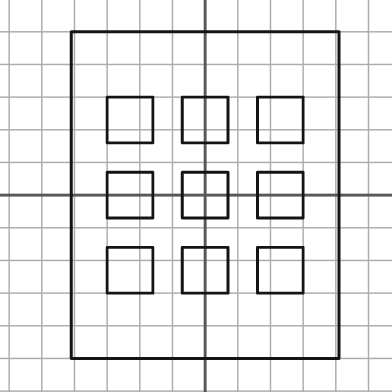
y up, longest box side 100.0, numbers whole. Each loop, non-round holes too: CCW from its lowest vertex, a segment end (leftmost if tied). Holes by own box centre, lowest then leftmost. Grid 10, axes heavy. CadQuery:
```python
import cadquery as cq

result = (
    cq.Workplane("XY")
    .moveTo(-41.0, -50.0)
    .lineTo(41.0, -50.0)
    .lineTo(41.0, 50.0)
    .lineTo(-41.0, 50.0)
    .close()
    .moveTo(-30.0, -30.0)
    .lineTo(-16.0, -30.0)
    .lineTo(-16.0, -16.0)
    .lineTo(-30.0, -16.0)
    .close()
    .moveTo(-7.0, -30.0)
    .lineTo(7.0, -30.0)
    .lineTo(7.0, -16.0)
    .lineTo(-7.0, -16.0)
    .close()
    .moveTo(16.0, -30.0)
    .lineTo(30.0, -30.0)
    .lineTo(30.0, -16.0)
    .lineTo(16.0, -16.0)
    .close()
    .moveTo(-30.0, -7.0)
    .lineTo(-16.0, -7.0)
    .lineTo(-16.0, 7.0)
    .lineTo(-30.0, 7.0)
    .close()
    .moveTo(-7.0, -7.0)
    .lineTo(7.0, -7.0)
    .lineTo(7.0, 7.0)
    .lineTo(-7.0, 7.0)
    .close()
    .moveTo(16.0, -7.0)
    .lineTo(30.0, -7.0)
    .lineTo(30.0, 7.0)
    .lineTo(16.0, 7.0)
    .close()
    .moveTo(-30.0, 16.0)
    .lineTo(-16.0, 16.0)
    .lineTo(-16.0, 30.0)
    .lineTo(-30.0, 30.0)
    .close()
    .moveTo(-7.0, 16.0)
    .lineTo(7.0, 16.0)
    .lineTo(7.0, 30.0)
    .lineTo(-7.0, 30.0)
    .close()
    .moveTo(16.0, 16.0)
    .lineTo(30.0, 16.0)
    .lineTo(30.0, 30.0)
    .lineTo(16.0, 30.0)
    .close()
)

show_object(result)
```